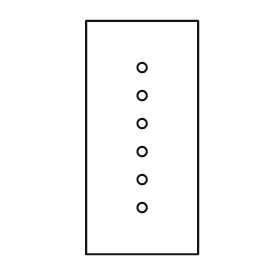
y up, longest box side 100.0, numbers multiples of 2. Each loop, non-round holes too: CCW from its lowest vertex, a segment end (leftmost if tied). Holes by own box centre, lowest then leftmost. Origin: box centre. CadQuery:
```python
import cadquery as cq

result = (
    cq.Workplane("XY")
    .moveTo(-24.0, -50.0)
    .lineTo(24.0, -50.0)
    .lineTo(24.0, 50.0)
    .lineTo(-24.0, 50.0)
    .close()
    .moveTo(0.0, -30.0)
    .circle(2.0)
    .moveTo(0.0, -18.0)
    .circle(2.0)
    .moveTo(0.0, -6.0)
    .circle(2.0)
    .moveTo(0.0, 6.0)
    .circle(2.0)
    .moveTo(0.0, 18.0)
    .circle(2.0)
    .moveTo(0.0, 30.0)
    .circle(2.0)
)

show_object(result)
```